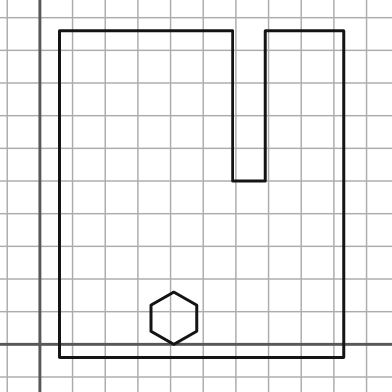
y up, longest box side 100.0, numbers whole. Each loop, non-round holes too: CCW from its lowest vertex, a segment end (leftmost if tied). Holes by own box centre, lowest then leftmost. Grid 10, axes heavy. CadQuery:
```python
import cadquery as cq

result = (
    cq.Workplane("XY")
    .moveTo(6.0, -4.0)
    .lineTo(93.0, -4.0)
    .lineTo(93.0, 96.0)
    .lineTo(69.0, 96.0)
    .lineTo(69.0, 50.0)
    .lineTo(59.0, 50.0)
    .lineTo(59.0, 96.0)
    .lineTo(6.0, 96.0)
    .close()
    .moveTo(41.0, 0.0)
    .lineTo(48.0, 4.0)
    .lineTo(48.0, 12.0)
    .lineTo(41.0, 16.0)
    .lineTo(34.0, 12.0)
    .lineTo(34.0, 4.0)
    .close()
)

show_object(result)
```